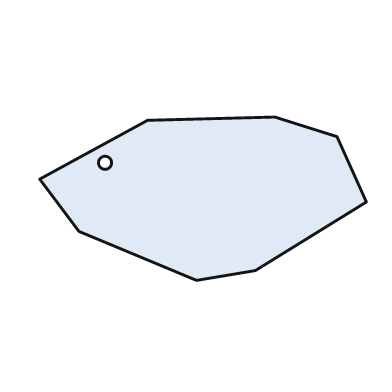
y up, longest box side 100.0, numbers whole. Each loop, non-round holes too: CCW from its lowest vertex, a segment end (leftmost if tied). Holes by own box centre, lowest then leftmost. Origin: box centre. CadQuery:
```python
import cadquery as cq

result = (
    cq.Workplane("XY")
    .moveTo(-2.0, -25.0)
    .lineTo(16.0, -22.0)
    .lineTo(50.0, -1.0)
    .lineTo(41.0, 19.0)
    .lineTo(22.0, 25.0)
    .lineTo(-17.0, 24.0)
    .lineTo(-50.0, 6.0)
    .lineTo(-38.0, -10.0)
    .close()
    .moveTo(-30.0, 11.0)
    .circle(2.0)
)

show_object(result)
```